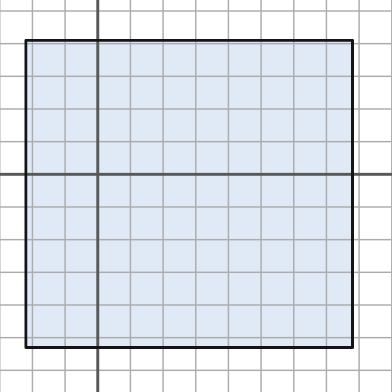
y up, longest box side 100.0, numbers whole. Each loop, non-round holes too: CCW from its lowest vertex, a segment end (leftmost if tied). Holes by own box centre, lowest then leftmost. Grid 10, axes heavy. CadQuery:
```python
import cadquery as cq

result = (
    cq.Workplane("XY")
    .moveTo(-22.0, -53.0)
    .lineTo(78.0, -53.0)
    .lineTo(78.0, 41.0)
    .lineTo(-22.0, 41.0)
    .close()
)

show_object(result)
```